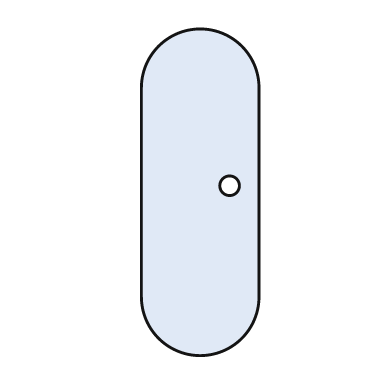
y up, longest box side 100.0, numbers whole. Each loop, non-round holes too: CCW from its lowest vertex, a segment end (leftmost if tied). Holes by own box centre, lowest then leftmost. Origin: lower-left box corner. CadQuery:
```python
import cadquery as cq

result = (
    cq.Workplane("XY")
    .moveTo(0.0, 18.0)
    .threePointArc((18.0, 0.0), (36.0, 18.0))
    .lineTo(36.0, 82.0)
    .threePointArc((18.0, 100.0), (0.0, 82.0))
    .close()
    .moveTo(27.0, 52.0)
    .circle(3.0)
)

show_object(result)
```